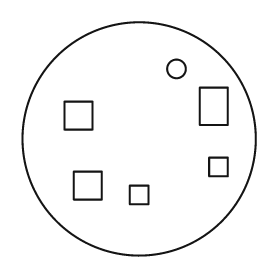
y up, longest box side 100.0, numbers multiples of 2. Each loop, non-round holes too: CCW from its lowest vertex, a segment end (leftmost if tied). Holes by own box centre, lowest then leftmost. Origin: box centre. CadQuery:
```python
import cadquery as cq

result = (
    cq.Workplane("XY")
    .moveTo(0.0, 0.0)
    .circle(50.0)
    .moveTo(-4.0, -28.0)
    .lineTo(4.0, -28.0)
    .lineTo(4.0, -20.0)
    .lineTo(-4.0, -20.0)
    .close()
    .moveTo(-28.0, -26.0)
    .lineTo(-16.0, -26.0)
    .lineTo(-16.0, -14.0)
    .lineTo(-28.0, -14.0)
    .close()
    .moveTo(30.0, -16.0)
    .lineTo(38.0, -16.0)
    .lineTo(38.0, -8.0)
    .lineTo(30.0, -8.0)
    .close()
    .moveTo(-32.0, 4.0)
    .lineTo(-20.0, 4.0)
    .lineTo(-20.0, 16.0)
    .lineTo(-32.0, 16.0)
    .close()
    .moveTo(26.0, 6.0)
    .lineTo(38.0, 6.0)
    .lineTo(38.0, 22.0)
    .lineTo(26.0, 22.0)
    .close()
    .moveTo(16.0, 30.0)
    .circle(4.0)
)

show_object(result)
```